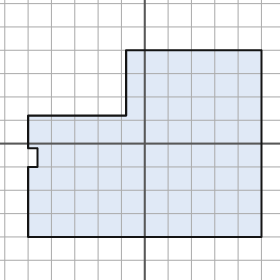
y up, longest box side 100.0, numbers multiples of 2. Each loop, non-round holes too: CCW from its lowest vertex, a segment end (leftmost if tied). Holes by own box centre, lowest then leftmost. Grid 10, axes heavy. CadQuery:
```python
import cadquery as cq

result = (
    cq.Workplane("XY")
    .moveTo(-50.0, -40.0)
    .lineTo(50.0, -40.0)
    .lineTo(50.0, 40.0)
    .lineTo(-8.0, 40.0)
    .lineTo(-8.0, 12.0)
    .lineTo(-50.0, 12.0)
    .lineTo(-50.0, -2.0)
    .lineTo(-46.0, -2.0)
    .lineTo(-46.0, -10.0)
    .lineTo(-50.0, -10.0)
    .close()
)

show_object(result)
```